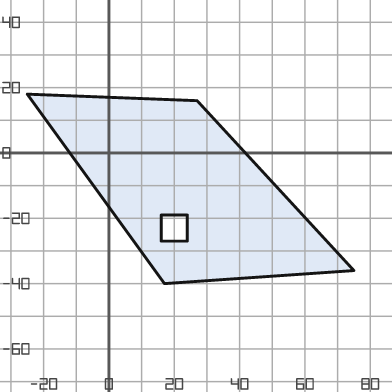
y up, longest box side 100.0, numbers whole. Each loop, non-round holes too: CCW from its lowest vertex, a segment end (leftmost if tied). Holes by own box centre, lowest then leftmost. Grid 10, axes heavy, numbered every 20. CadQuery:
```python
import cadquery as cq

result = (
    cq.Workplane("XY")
    .moveTo(17.0, -40.0)
    .lineTo(75.0, -36.0)
    .lineTo(27.0, 16.0)
    .lineTo(-25.0, 18.0)
    .close()
    .moveTo(16.0, -27.0)
    .lineTo(24.0, -27.0)
    .lineTo(24.0, -19.0)
    .lineTo(16.0, -19.0)
    .close()
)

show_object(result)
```